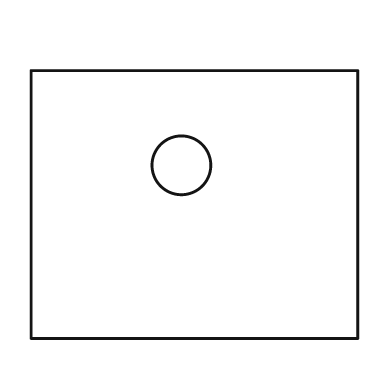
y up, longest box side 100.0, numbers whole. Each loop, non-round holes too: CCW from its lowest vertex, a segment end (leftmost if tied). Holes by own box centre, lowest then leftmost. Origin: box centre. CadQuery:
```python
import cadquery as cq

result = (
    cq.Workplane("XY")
    .moveTo(-50.0, -41.0)
    .lineTo(50.0, -41.0)
    .lineTo(50.0, 41.0)
    .lineTo(-50.0, 41.0)
    .close()
    .moveTo(-4.0, 12.0)
    .circle(9.0)
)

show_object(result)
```